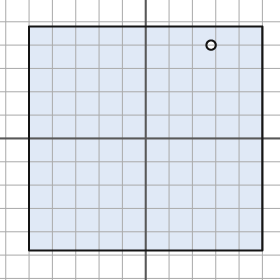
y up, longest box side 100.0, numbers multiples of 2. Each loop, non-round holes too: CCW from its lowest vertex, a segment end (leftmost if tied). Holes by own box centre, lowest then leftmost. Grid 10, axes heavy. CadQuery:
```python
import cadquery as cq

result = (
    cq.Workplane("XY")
    .moveTo(-50.0, -48.0)
    .lineTo(50.0, -48.0)
    .lineTo(50.0, 48.0)
    .lineTo(-50.0, 48.0)
    .close()
    .moveTo(28.0, 40.0)
    .circle(2.0)
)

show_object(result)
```